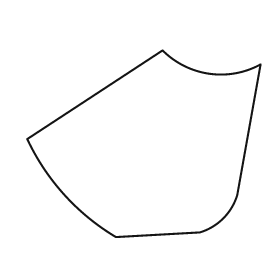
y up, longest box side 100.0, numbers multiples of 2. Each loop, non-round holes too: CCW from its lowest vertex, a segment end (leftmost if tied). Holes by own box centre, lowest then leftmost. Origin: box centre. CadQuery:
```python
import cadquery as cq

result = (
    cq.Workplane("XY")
    .moveTo(-12.0, -40.0)
    .lineTo(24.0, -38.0)
    .threePointArc((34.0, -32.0), (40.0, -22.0))
    .lineTo(50.0, 34.0)
    .threePointArc((28.0, 30.0), (8.0, 40.0))
    .lineTo(-50.0, 2.0)
    .threePointArc((-34.0, -22.0), (-12.0, -40.0))
    .close()
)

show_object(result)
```